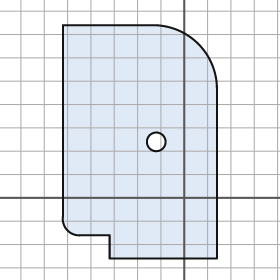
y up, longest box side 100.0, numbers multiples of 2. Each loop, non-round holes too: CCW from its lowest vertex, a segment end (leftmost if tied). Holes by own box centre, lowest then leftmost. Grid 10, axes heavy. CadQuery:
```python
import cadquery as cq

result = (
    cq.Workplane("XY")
    .moveTo(-32.0, -26.0)
    .lineTo(14.0, -26.0)
    .lineTo(14.0, 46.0)
    .threePointArc((6.0, 66.0), (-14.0, 74.0))
    .lineTo(-52.0, 74.0)
    .lineTo(-52.0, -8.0)
    .threePointArc((-50.0, -14.0), (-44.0, -16.0))
    .lineTo(-32.0, -16.0)
    .close()
    .moveTo(-12.0, 24.0)
    .circle(4.0)
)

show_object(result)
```